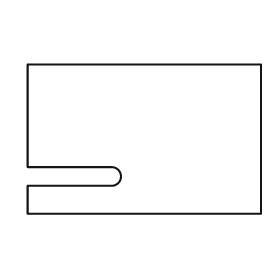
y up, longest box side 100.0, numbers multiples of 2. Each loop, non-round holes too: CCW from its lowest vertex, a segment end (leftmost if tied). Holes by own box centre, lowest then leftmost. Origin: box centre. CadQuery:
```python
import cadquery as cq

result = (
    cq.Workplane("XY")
    .moveTo(-50.0, -32.0)
    .lineTo(50.0, -32.0)
    .lineTo(50.0, 32.0)
    .lineTo(-50.0, 32.0)
    .lineTo(-50.0, -12.0)
    .lineTo(-14.0, -12.0)
    .threePointArc((-10.0, -16.0), (-14.0, -20.0))
    .lineTo(-50.0, -20.0)
    .close()
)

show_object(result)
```